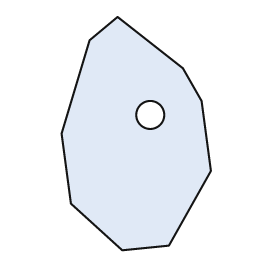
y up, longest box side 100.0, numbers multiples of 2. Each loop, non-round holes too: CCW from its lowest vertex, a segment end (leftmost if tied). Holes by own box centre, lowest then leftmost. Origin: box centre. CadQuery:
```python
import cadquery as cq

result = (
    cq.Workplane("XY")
    .moveTo(-6.0, -50.0)
    .lineTo(14.0, -48.0)
    .lineTo(32.0, -16.0)
    .lineTo(28.0, 14.0)
    .lineTo(20.0, 28.0)
    .lineTo(-8.0, 50.0)
    .lineTo(-20.0, 40.0)
    .lineTo(-32.0, 0.0)
    .lineTo(-28.0, -30.0)
    .close()
    .moveTo(6.0, 8.0)
    .circle(6.0)
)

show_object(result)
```